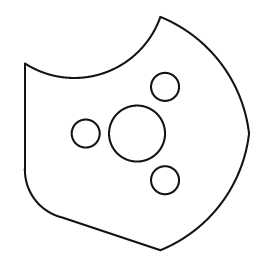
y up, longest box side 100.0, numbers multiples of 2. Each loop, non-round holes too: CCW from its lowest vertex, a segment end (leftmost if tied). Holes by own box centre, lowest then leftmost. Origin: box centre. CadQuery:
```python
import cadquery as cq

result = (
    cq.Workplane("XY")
    .moveTo(10.0, -50.0)
    .threePointArc((36.0, -30.0), (48.0, 0.0))
    .threePointArc((36.0, 30.0), (10.0, 50.0))
    .threePointArc((-14.0, 26.0), (-48.0, 30.0))
    .lineTo(-48.0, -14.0)
    .threePointArc((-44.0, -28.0), (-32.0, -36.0))
    .close()
    .moveTo(12.0, -20.0)
    .circle(6.0)
    .moveTo(-22.0, 0.0)
    .circle(6.0)
    .moveTo(0.0, 0.0)
    .circle(12.0)
    .moveTo(12.0, 20.0)
    .circle(6.0)
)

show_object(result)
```